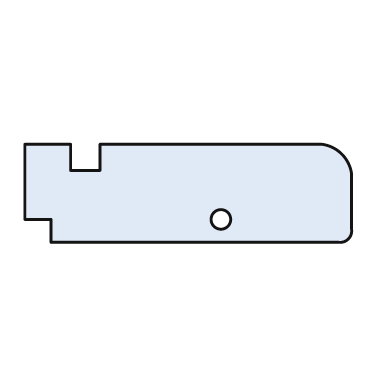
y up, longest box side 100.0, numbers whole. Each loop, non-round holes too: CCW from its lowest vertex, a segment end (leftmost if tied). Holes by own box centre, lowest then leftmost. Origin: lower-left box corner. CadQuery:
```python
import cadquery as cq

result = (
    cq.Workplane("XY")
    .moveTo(8.0, 0.0)
    .lineTo(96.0, 0.0)
    .threePointArc((99.0, 1.0), (100.0, 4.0))
    .lineTo(100.0, 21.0)
    .threePointArc((97.0, 27.0), (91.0, 30.0))
    .lineTo(23.0, 30.0)
    .lineTo(23.0, 22.0)
    .lineTo(14.0, 22.0)
    .lineTo(14.0, 30.0)
    .lineTo(0.0, 30.0)
    .lineTo(0.0, 7.0)
    .lineTo(8.0, 7.0)
    .close()
    .moveTo(60.0, 7.0)
    .circle(3.0)
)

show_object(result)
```